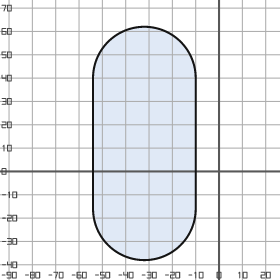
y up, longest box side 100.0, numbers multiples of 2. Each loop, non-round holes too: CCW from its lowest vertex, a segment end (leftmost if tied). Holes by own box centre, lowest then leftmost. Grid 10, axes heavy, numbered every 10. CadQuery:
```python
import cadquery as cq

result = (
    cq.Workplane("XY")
    .moveTo(-54.0, -16.0)
    .threePointArc((-32.0, -38.0), (-10.0, -16.0))
    .lineTo(-10.0, 40.0)
    .threePointArc((-32.0, 62.0), (-54.0, 40.0))
    .close()
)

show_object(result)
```